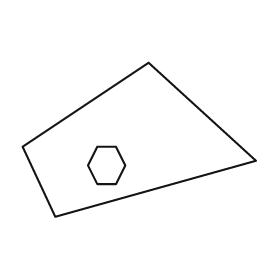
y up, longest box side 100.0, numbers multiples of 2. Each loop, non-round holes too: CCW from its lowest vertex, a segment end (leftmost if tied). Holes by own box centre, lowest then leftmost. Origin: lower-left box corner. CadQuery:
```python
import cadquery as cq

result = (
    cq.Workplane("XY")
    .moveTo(14.0, 0.0)
    .lineTo(100.0, 24.0)
    .lineTo(54.0, 66.0)
    .lineTo(0.0, 30.0)
    .close()
    .moveTo(32.0, 14.0)
    .lineTo(40.0, 14.0)
    .lineTo(44.0, 22.0)
    .lineTo(40.0, 30.0)
    .lineTo(32.0, 30.0)
    .lineTo(28.0, 22.0)
    .close()
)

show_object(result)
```